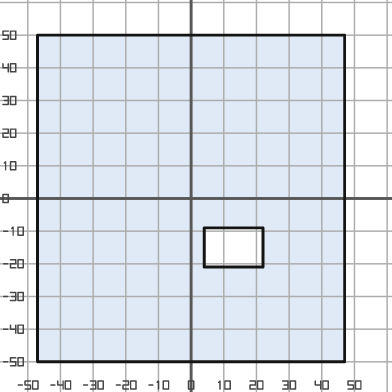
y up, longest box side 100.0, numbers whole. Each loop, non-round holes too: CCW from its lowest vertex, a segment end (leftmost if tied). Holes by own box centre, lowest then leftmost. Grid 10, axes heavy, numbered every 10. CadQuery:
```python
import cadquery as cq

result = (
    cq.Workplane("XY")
    .moveTo(-47.0, -50.0)
    .lineTo(47.0, -50.0)
    .lineTo(47.0, 50.0)
    .lineTo(-47.0, 50.0)
    .close()
    .moveTo(4.0, -21.0)
    .lineTo(22.0, -21.0)
    .lineTo(22.0, -9.0)
    .lineTo(4.0, -9.0)
    .close()
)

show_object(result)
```